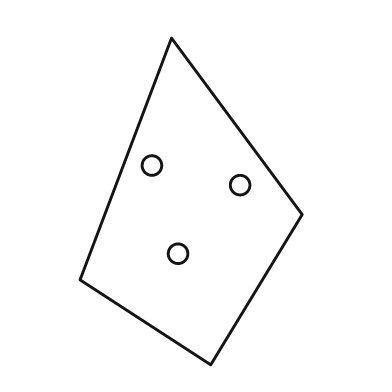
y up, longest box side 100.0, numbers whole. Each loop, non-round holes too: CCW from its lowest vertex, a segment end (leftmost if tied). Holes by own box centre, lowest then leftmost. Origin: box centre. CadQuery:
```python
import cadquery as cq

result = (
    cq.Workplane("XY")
    .moveTo(6.0, -50.0)
    .lineTo(34.0, -4.0)
    .lineTo(-6.0, 50.0)
    .lineTo(-34.0, -24.0)
    .close()
    .moveTo(-4.0, -16.0)
    .circle(3.0)
    .moveTo(15.0, 5.0)
    .circle(3.0)
    .moveTo(-12.0, 11.0)
    .circle(3.0)
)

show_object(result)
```